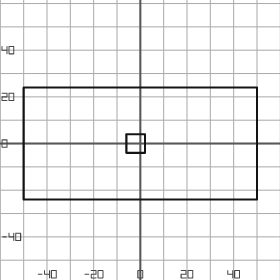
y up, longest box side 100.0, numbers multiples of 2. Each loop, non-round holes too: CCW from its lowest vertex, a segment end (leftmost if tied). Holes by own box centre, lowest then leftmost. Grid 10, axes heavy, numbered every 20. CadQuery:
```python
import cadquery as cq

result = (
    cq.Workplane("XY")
    .moveTo(-50.0, -24.0)
    .lineTo(50.0, -24.0)
    .lineTo(50.0, 24.0)
    .lineTo(-50.0, 24.0)
    .close()
    .moveTo(-6.0, -4.0)
    .lineTo(2.0, -4.0)
    .lineTo(2.0, 4.0)
    .lineTo(-6.0, 4.0)
    .close()
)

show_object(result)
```